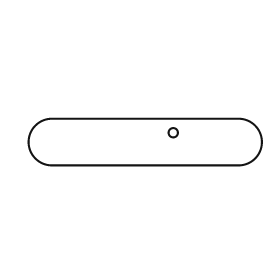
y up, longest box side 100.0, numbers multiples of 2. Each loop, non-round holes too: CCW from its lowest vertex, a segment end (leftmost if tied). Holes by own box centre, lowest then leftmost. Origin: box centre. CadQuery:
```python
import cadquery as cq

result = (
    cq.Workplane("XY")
    .moveTo(-40.0, -10.0)
    .lineTo(40.0, -10.0)
    .threePointArc((50.0, 0.0), (40.0, 10.0))
    .lineTo(-40.0, 10.0)
    .threePointArc((-50.0, 0.0), (-40.0, -10.0))
    .close()
    .moveTo(12.0, 4.0)
    .circle(2.0)
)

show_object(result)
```